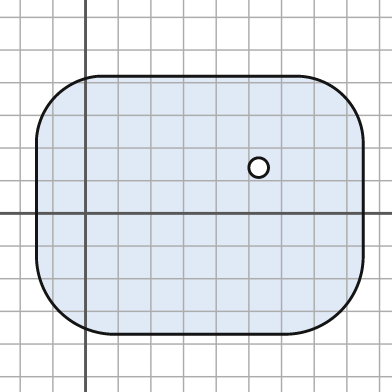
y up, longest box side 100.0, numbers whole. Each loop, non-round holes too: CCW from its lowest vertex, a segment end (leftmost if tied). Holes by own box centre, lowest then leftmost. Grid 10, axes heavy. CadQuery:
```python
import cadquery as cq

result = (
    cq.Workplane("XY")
    .moveTo(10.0, -37.0)
    .lineTo(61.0, -37.0)
    .threePointArc((78.0, -30.0), (85.0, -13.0))
    .lineTo(85.0, 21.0)
    .threePointArc((79.0, 36.0), (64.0, 42.0))
    .lineTo(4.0, 42.0)
    .threePointArc((-9.0, 36.0), (-15.0, 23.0))
    .lineTo(-15.0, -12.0)
    .threePointArc((-8.0, -30.0), (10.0, -37.0))
    .close()
    .moveTo(53.0, 14.0)
    .circle(3.0)
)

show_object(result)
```